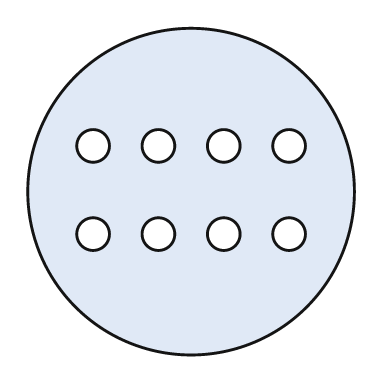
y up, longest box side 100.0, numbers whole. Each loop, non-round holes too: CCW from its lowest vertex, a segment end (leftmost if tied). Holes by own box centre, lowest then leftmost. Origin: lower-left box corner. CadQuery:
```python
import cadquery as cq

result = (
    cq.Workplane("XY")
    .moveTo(50.0, 50.0)
    .circle(50.0)
    .moveTo(20.0, 37.0)
    .circle(5.0)
    .moveTo(40.0, 37.0)
    .circle(5.0)
    .moveTo(60.0, 37.0)
    .circle(5.0)
    .moveTo(80.0, 37.0)
    .circle(5.0)
    .moveTo(20.0, 64.0)
    .circle(5.0)
    .moveTo(40.0, 64.0)
    .circle(5.0)
    .moveTo(60.0, 64.0)
    .circle(5.0)
    .moveTo(80.0, 64.0)
    .circle(5.0)
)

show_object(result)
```